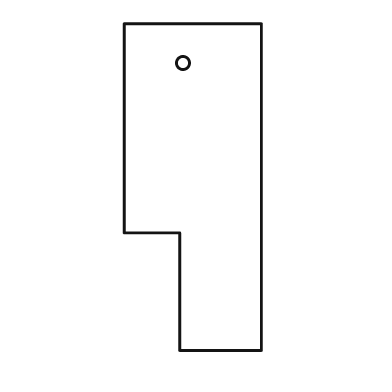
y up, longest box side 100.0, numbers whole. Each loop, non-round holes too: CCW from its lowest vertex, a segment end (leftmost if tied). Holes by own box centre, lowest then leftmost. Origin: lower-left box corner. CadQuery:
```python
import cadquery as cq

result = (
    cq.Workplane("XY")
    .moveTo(17.0, 0.0)
    .lineTo(42.0, 0.0)
    .lineTo(42.0, 100.0)
    .lineTo(0.0, 100.0)
    .lineTo(0.0, 36.0)
    .lineTo(17.0, 36.0)
    .close()
    .moveTo(18.0, 88.0)
    .circle(2.0)
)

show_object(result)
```